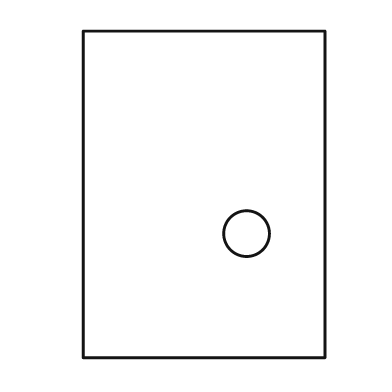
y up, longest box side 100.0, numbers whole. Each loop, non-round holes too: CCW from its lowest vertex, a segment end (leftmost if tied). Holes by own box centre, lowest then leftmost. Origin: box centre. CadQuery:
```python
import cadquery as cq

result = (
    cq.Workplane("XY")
    .moveTo(-37.0, -50.0)
    .lineTo(37.0, -50.0)
    .lineTo(37.0, 50.0)
    .lineTo(-37.0, 50.0)
    .close()
    .moveTo(13.0, -12.0)
    .circle(7.0)
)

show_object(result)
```